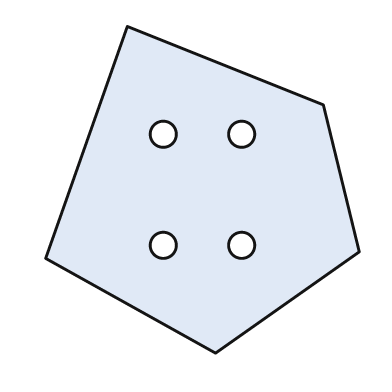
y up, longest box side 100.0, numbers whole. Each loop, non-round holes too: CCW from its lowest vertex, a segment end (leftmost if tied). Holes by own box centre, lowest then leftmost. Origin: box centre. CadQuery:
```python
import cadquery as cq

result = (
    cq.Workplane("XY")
    .moveTo(4.0, -50.0)
    .lineTo(48.0, -19.0)
    .lineTo(37.0, 26.0)
    .lineTo(-23.0, 50.0)
    .lineTo(-48.0, -21.0)
    .close()
    .moveTo(-12.0, -17.0)
    .circle(4.0)
    .moveTo(12.0, -17.0)
    .circle(4.0)
    .moveTo(-12.0, 17.0)
    .circle(4.0)
    .moveTo(12.0, 17.0)
    .circle(4.0)
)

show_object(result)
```